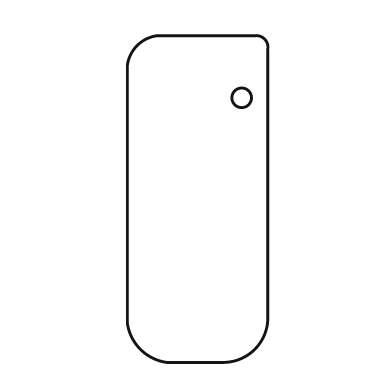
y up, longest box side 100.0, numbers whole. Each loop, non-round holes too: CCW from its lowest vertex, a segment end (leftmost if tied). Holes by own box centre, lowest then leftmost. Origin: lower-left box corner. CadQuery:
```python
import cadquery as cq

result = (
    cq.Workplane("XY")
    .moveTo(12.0, 0.0)
    .lineTo(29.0, 0.0)
    .threePointArc((39.0, 4.0), (43.0, 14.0))
    .lineTo(43.0, 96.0)
    .threePointArc((42.0, 99.0), (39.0, 100.0))
    .lineTo(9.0, 100.0)
    .threePointArc((3.0, 97.0), (0.0, 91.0))
    .lineTo(0.0, 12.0)
    .threePointArc((4.0, 4.0), (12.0, 0.0))
    .close()
    .moveTo(35.0, 81.0)
    .circle(3.0)
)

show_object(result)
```